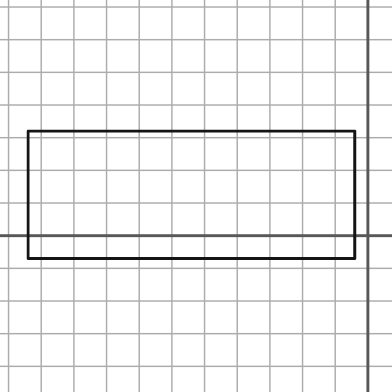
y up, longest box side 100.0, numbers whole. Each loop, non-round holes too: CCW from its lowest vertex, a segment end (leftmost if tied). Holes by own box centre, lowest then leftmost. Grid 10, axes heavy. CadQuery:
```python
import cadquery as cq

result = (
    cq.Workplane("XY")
    .moveTo(-104.0, -7.0)
    .lineTo(-4.0, -7.0)
    .lineTo(-4.0, 32.0)
    .lineTo(-104.0, 32.0)
    .close()
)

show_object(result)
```